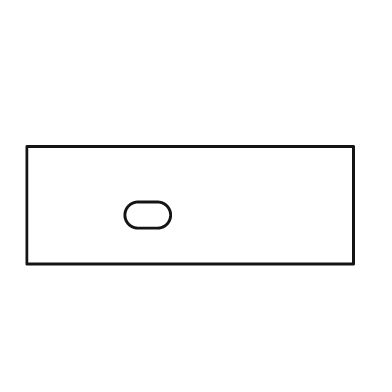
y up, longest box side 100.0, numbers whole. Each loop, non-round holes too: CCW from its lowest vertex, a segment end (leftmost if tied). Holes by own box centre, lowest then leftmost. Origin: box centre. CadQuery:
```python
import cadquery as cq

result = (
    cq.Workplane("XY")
    .moveTo(-50.0, -18.0)
    .lineTo(50.0, -18.0)
    .lineTo(50.0, 18.0)
    .lineTo(-50.0, 18.0)
    .close()
    .moveTo(-16.0, -7.0)
    .lineTo(-10.0, -7.0)
    .threePointArc((-6.0, -3.0), (-10.0, 1.0))
    .lineTo(-16.0, 1.0)
    .threePointArc((-20.0, -3.0), (-16.0, -7.0))
    .close()
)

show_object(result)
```